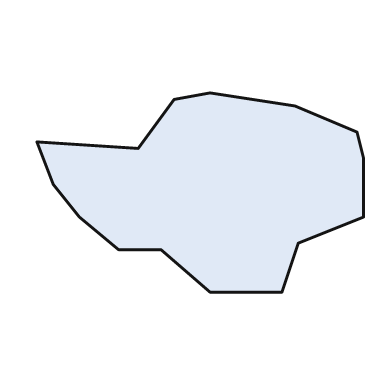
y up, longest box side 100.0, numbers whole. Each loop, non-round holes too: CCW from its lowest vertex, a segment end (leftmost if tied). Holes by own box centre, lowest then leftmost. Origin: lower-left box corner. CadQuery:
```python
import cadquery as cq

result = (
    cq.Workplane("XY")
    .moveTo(53.0, 0.0)
    .lineTo(75.0, 0.0)
    .lineTo(80.0, 15.0)
    .lineTo(100.0, 23.0)
    .lineTo(100.0, 41.0)
    .lineTo(98.0, 49.0)
    .lineTo(79.0, 57.0)
    .lineTo(53.0, 61.0)
    .lineTo(42.0, 59.0)
    .lineTo(31.0, 44.0)
    .lineTo(0.0, 46.0)
    .lineTo(5.0, 33.0)
    .lineTo(13.0, 23.0)
    .lineTo(25.0, 13.0)
    .lineTo(38.0, 13.0)
    .close()
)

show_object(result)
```